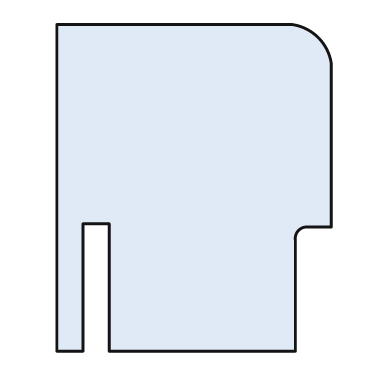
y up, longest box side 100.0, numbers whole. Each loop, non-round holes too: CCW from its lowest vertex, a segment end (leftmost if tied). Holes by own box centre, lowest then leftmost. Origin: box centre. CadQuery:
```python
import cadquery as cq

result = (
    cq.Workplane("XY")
    .moveTo(-42.0, -50.0)
    .lineTo(-34.0, -50.0)
    .lineTo(-34.0, -11.0)
    .lineTo(-26.0, -11.0)
    .lineTo(-26.0, -50.0)
    .lineTo(31.0, -50.0)
    .lineTo(31.0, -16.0)
    .threePointArc((32.0, -13.0), (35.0, -12.0))
    .lineTo(42.0, -12.0)
    .lineTo(42.0, 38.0)
    .threePointArc((38.0, 46.0), (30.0, 50.0))
    .lineTo(-42.0, 50.0)
    .close()
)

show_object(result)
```